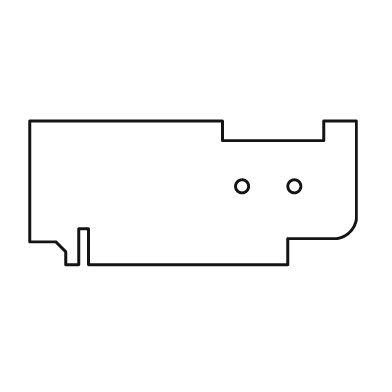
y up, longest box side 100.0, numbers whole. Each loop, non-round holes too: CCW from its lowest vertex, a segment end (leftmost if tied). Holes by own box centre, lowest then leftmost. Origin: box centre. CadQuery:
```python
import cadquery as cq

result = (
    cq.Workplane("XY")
    .moveTo(-39.0, -22.0)
    .lineTo(-35.0, -22.0)
    .lineTo(-35.0, -11.0)
    .lineTo(-32.0, -11.0)
    .lineTo(-32.0, -22.0)
    .lineTo(29.0, -22.0)
    .lineTo(29.0, -14.0)
    .lineTo(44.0, -14.0)
    .threePointArc((48.0, -12.0), (50.0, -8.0))
    .lineTo(50.0, 22.0)
    .lineTo(40.0, 22.0)
    .lineTo(40.0, 16.0)
    .lineTo(9.0, 16.0)
    .lineTo(9.0, 22.0)
    .lineTo(-50.0, 22.0)
    .lineTo(-50.0, -15.0)
    .lineTo(-42.0, -15.0)
    .lineTo(-39.0, -18.0)
    .close()
    .moveTo(15.0, 2.0)
    .circle(2.0)
    .moveTo(31.0, 2.0)
    .circle(2.0)
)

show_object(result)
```